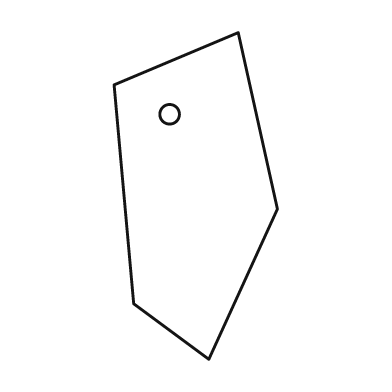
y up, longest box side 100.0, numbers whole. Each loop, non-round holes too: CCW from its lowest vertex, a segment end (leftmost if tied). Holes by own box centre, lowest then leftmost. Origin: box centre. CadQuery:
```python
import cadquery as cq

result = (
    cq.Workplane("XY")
    .moveTo(4.0, -50.0)
    .lineTo(25.0, -4.0)
    .lineTo(13.0, 50.0)
    .lineTo(-25.0, 34.0)
    .lineTo(-19.0, -33.0)
    .close()
    .moveTo(-8.0, 25.0)
    .circle(3.0)
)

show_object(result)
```